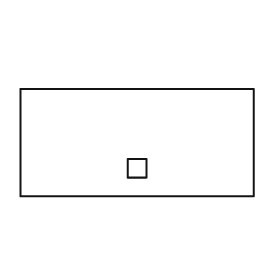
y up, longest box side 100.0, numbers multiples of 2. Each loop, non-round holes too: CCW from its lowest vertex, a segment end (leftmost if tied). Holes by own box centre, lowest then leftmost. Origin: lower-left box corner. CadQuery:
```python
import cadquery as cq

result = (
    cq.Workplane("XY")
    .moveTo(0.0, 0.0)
    .lineTo(100.0, 0.0)
    .lineTo(100.0, 46.0)
    .lineTo(0.0, 46.0)
    .close()
    .moveTo(46.0, 8.0)
    .lineTo(54.0, 8.0)
    .lineTo(54.0, 16.0)
    .lineTo(46.0, 16.0)
    .close()
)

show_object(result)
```